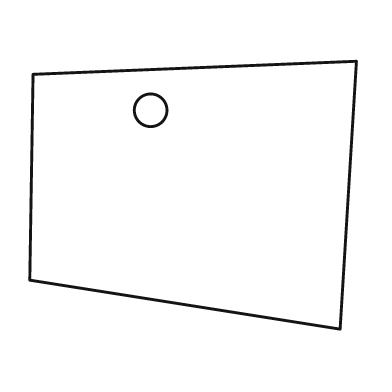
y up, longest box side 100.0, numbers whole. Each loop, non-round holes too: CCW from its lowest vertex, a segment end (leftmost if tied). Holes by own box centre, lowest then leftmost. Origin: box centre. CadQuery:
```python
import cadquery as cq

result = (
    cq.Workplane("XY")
    .moveTo(45.0, -41.0)
    .lineTo(50.0, 41.0)
    .lineTo(-49.0, 37.0)
    .lineTo(-50.0, -26.0)
    .close()
    .moveTo(-13.0, 26.0)
    .circle(5.0)
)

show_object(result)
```